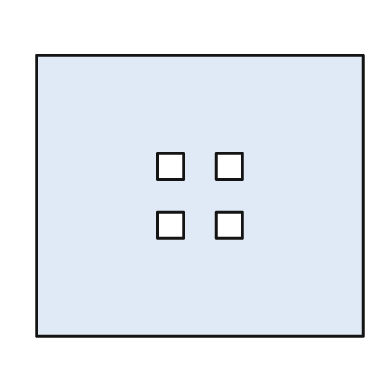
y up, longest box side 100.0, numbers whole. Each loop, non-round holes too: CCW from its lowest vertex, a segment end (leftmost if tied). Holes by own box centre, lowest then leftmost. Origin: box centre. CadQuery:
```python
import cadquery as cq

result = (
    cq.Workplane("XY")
    .moveTo(-50.0, -43.0)
    .lineTo(50.0, -43.0)
    .lineTo(50.0, 43.0)
    .lineTo(-50.0, 43.0)
    .close()
    .moveTo(-13.0, -13.0)
    .lineTo(-5.0, -13.0)
    .lineTo(-5.0, -5.0)
    .lineTo(-13.0, -5.0)
    .close()
    .moveTo(5.0, -13.0)
    .lineTo(13.0, -13.0)
    .lineTo(13.0, -5.0)
    .lineTo(5.0, -5.0)
    .close()
    .moveTo(-13.0, 5.0)
    .lineTo(-5.0, 5.0)
    .lineTo(-5.0, 13.0)
    .lineTo(-13.0, 13.0)
    .close()
    .moveTo(5.0, 5.0)
    .lineTo(13.0, 5.0)
    .lineTo(13.0, 13.0)
    .lineTo(5.0, 13.0)
    .close()
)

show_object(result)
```